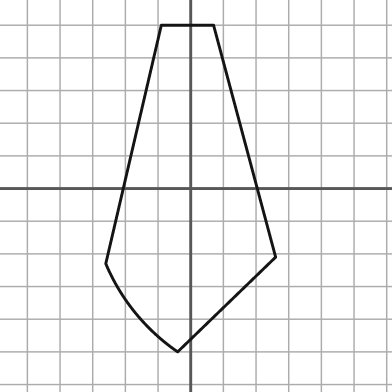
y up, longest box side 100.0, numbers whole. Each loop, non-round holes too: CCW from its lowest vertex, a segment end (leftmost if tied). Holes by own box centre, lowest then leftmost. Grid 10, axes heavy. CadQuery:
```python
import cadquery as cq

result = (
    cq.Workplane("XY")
    .moveTo(-4.0, -50.0)
    .lineTo(26.0, -21.0)
    .lineTo(7.0, 50.0)
    .lineTo(-9.0, 50.0)
    .lineTo(-26.0, -23.0)
    .threePointArc((-17.0, -38.0), (-4.0, -50.0))
    .close()
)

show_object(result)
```